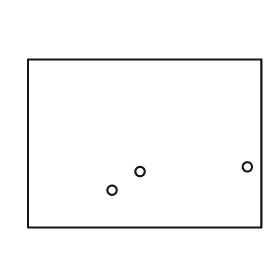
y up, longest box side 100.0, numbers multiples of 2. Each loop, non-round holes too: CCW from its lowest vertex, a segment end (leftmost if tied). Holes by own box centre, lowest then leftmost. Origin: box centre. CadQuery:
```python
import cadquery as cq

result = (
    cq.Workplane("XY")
    .moveTo(-50.0, -36.0)
    .lineTo(50.0, -36.0)
    .lineTo(50.0, 36.0)
    .lineTo(-50.0, 36.0)
    .close()
    .moveTo(-14.0, -20.0)
    .circle(2.0)
    .moveTo(-2.0, -12.0)
    .circle(2.0)
    .moveTo(44.0, -10.0)
    .circle(2.0)
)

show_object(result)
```